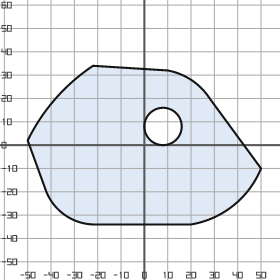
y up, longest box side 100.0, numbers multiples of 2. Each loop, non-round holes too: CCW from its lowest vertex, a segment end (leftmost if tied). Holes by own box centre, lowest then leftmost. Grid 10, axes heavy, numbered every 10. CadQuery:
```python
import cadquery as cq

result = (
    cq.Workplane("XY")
    .moveTo(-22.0, -34.0)
    .lineTo(20.0, -34.0)
    .threePointArc((38.0, -26.0), (50.0, -10.0))
    .lineTo(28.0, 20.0)
    .threePointArc((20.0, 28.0), (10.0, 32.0))
    .lineTo(-22.0, 34.0)
    .threePointArc((-38.0, 20.0), (-50.0, 2.0))
    .lineTo(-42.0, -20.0)
    .threePointArc((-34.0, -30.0), (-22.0, -34.0))
    .close()
    .moveTo(8.0, 8.0)
    .circle(8.0)
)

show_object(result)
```